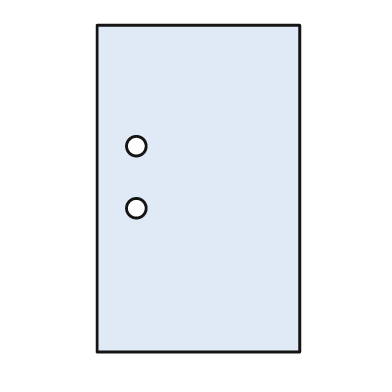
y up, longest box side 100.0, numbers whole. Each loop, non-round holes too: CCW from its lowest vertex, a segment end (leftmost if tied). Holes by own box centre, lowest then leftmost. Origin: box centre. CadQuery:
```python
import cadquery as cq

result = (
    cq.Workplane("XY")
    .moveTo(-31.0, -50.0)
    .lineTo(31.0, -50.0)
    .lineTo(31.0, 50.0)
    .lineTo(-31.0, 50.0)
    .close()
    .moveTo(-19.0, -6.0)
    .circle(3.0)
    .moveTo(-19.0, 13.0)
    .circle(3.0)
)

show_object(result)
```